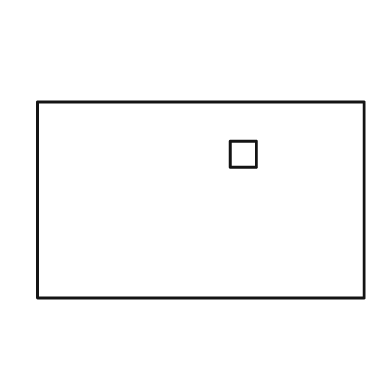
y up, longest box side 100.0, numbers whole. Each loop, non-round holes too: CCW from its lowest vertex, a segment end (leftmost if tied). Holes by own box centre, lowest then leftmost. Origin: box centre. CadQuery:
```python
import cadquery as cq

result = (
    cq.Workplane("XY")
    .moveTo(-50.0, -30.0)
    .lineTo(50.0, -30.0)
    .lineTo(50.0, 30.0)
    .lineTo(-50.0, 30.0)
    .close()
    .moveTo(9.0, 10.0)
    .lineTo(17.0, 10.0)
    .lineTo(17.0, 18.0)
    .lineTo(9.0, 18.0)
    .close()
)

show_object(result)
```